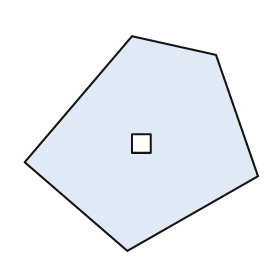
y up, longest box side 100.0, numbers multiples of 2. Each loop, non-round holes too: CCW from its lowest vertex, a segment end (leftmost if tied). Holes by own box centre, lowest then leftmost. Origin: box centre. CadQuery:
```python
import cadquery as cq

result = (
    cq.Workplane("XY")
    .moveTo(-6.0, -46.0)
    .lineTo(50.0, -14.0)
    .lineTo(32.0, 38.0)
    .lineTo(-4.0, 46.0)
    .lineTo(-50.0, -8.0)
    .close()
    .moveTo(-4.0, -4.0)
    .lineTo(4.0, -4.0)
    .lineTo(4.0, 4.0)
    .lineTo(-4.0, 4.0)
    .close()
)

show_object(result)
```